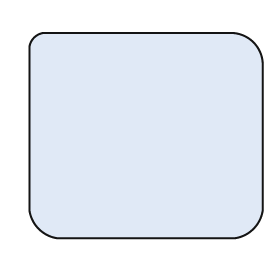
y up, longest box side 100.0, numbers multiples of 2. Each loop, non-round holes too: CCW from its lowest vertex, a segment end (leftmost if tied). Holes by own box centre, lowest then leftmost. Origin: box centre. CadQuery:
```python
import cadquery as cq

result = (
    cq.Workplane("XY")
    .moveTo(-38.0, -44.0)
    .lineTo(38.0, -44.0)
    .threePointArc((46.0, -40.0), (50.0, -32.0))
    .lineTo(50.0, 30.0)
    .threePointArc((46.0, 40.0), (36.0, 44.0))
    .lineTo(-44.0, 44.0)
    .threePointArc((-48.0, 42.0), (-50.0, 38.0))
    .lineTo(-50.0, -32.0)
    .threePointArc((-46.0, -40.0), (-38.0, -44.0))
    .close()
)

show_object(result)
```